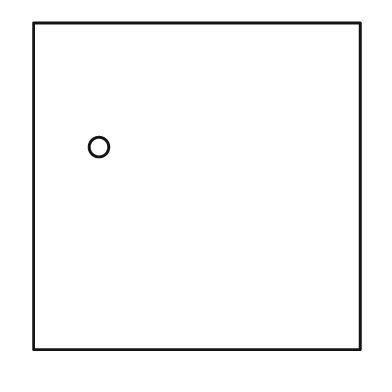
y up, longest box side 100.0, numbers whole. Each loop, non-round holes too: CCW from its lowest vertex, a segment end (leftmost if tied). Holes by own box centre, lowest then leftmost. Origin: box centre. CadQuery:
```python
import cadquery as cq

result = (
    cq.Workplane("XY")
    .moveTo(-50.0, -50.0)
    .lineTo(50.0, -50.0)
    .lineTo(50.0, 50.0)
    .lineTo(-50.0, 50.0)
    .close()
    .moveTo(-30.0, 12.0)
    .circle(3.0)
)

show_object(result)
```